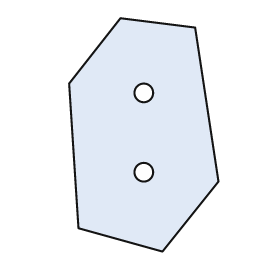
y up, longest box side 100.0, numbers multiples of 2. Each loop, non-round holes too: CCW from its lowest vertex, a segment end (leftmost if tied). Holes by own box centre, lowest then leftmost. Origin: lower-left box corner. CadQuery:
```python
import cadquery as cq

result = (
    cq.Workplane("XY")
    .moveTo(40.0, 0.0)
    .lineTo(64.0, 30.0)
    .lineTo(54.0, 96.0)
    .lineTo(22.0, 100.0)
    .lineTo(0.0, 72.0)
    .lineTo(4.0, 10.0)
    .close()
    .moveTo(32.0, 34.0)
    .circle(4.0)
    .moveTo(32.0, 68.0)
    .circle(4.0)
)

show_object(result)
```